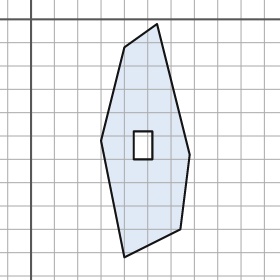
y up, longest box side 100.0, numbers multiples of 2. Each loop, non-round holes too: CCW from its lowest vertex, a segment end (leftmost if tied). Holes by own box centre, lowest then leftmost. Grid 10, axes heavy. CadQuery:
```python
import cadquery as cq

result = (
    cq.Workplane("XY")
    .moveTo(40.0, -102.0)
    .lineTo(64.0, -90.0)
    .lineTo(68.0, -58.0)
    .lineTo(54.0, -2.0)
    .lineTo(40.0, -12.0)
    .lineTo(30.0, -52.0)
    .close()
    .moveTo(44.0, -60.0)
    .lineTo(52.0, -60.0)
    .lineTo(52.0, -48.0)
    .lineTo(44.0, -48.0)
    .close()
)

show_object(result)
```